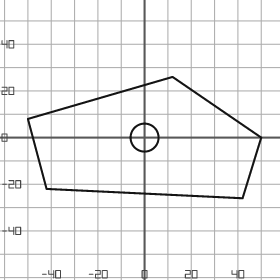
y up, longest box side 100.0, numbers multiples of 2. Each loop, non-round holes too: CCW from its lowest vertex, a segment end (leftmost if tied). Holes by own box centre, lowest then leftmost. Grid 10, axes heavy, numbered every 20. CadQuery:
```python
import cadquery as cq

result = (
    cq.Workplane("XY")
    .moveTo(42.0, -26.0)
    .lineTo(50.0, 0.0)
    .lineTo(12.0, 26.0)
    .lineTo(-50.0, 8.0)
    .lineTo(-42.0, -22.0)
    .close()
    .moveTo(0.0, 0.0)
    .circle(6.0)
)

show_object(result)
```